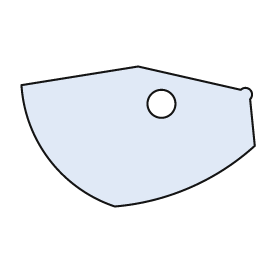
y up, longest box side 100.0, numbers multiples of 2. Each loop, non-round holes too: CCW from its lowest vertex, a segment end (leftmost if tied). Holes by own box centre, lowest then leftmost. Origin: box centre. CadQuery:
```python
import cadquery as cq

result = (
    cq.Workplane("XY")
    .moveTo(-10.0, -30.0)
    .threePointArc((22.0, -22.0), (50.0, -4.0))
    .lineTo(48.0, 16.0)
    .threePointArc((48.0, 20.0), (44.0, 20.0))
    .lineTo(0.0, 30.0)
    .lineTo(-50.0, 22.0)
    .threePointArc((-38.0, -10.0), (-10.0, -30.0))
    .close()
    .moveTo(10.0, 14.0)
    .circle(6.0)
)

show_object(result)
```